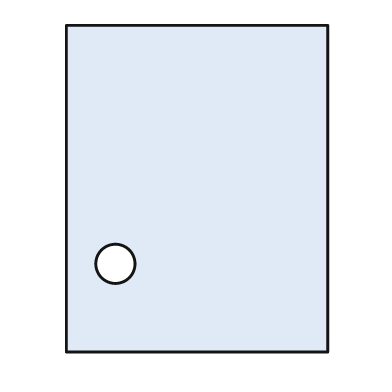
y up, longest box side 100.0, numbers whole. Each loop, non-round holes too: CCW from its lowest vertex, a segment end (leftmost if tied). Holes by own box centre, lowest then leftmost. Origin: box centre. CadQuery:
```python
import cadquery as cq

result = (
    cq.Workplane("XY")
    .moveTo(-40.0, -50.0)
    .lineTo(40.0, -50.0)
    .lineTo(40.0, 50.0)
    .lineTo(-40.0, 50.0)
    .close()
    .moveTo(-25.0, -23.0)
    .circle(6.0)
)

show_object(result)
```